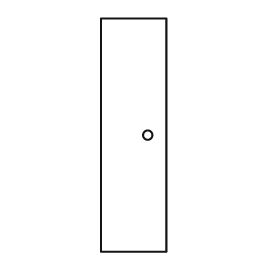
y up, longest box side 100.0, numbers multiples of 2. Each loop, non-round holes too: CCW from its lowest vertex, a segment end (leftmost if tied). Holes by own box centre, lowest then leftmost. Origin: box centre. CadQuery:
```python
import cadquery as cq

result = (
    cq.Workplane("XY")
    .moveTo(-14.0, -50.0)
    .lineTo(14.0, -50.0)
    .lineTo(14.0, 50.0)
    .lineTo(-14.0, 50.0)
    .close()
    .moveTo(6.0, 0.0)
    .circle(2.0)
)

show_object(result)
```